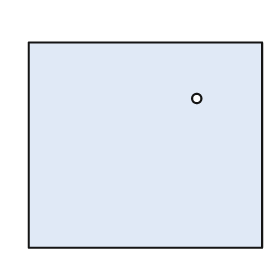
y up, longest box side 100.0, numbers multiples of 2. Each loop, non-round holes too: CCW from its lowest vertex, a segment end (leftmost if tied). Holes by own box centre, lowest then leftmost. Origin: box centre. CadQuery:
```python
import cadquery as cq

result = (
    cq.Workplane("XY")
    .moveTo(-50.0, -44.0)
    .lineTo(50.0, -44.0)
    .lineTo(50.0, 44.0)
    .lineTo(-50.0, 44.0)
    .close()
    .moveTo(22.0, 20.0)
    .circle(2.0)
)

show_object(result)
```